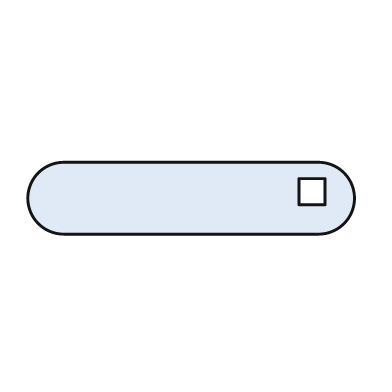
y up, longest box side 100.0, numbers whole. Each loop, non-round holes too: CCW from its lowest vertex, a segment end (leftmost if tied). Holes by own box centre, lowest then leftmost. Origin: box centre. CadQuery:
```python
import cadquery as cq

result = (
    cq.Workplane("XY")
    .moveTo(-39.0, -11.0)
    .lineTo(39.0, -11.0)
    .threePointArc((50.0, 0.0), (39.0, 11.0))
    .lineTo(-39.0, 11.0)
    .threePointArc((-50.0, 0.0), (-39.0, -11.0))
    .close()
    .moveTo(33.0, -2.0)
    .lineTo(41.0, -2.0)
    .lineTo(41.0, 6.0)
    .lineTo(33.0, 6.0)
    .close()
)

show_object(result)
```